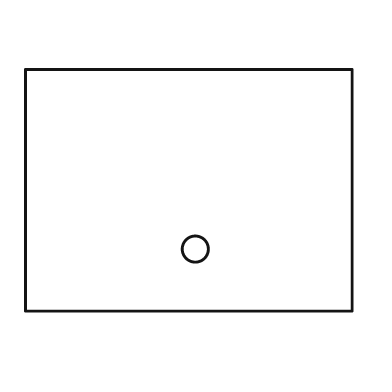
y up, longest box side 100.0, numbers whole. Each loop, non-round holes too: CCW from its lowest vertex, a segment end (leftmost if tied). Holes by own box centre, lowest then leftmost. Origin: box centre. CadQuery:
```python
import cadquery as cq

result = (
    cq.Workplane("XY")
    .moveTo(-50.0, -37.0)
    .lineTo(50.0, -37.0)
    .lineTo(50.0, 37.0)
    .lineTo(-50.0, 37.0)
    .close()
    .moveTo(2.0, -18.0)
    .circle(4.0)
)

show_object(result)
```